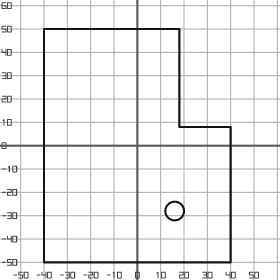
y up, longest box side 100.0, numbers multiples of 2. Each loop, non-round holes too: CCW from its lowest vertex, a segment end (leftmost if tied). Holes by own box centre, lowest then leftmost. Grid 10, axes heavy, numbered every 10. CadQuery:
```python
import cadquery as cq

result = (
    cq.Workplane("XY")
    .moveTo(-40.0, -50.0)
    .lineTo(40.0, -50.0)
    .lineTo(40.0, 8.0)
    .lineTo(18.0, 8.0)
    .lineTo(18.0, 50.0)
    .lineTo(-40.0, 50.0)
    .close()
    .moveTo(16.0, -28.0)
    .circle(4.0)
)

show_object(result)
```